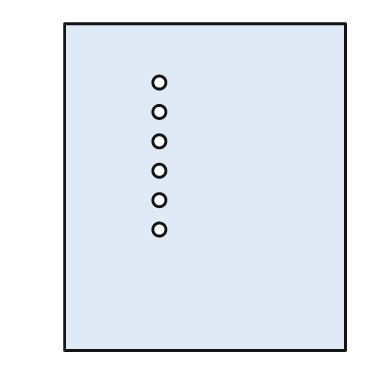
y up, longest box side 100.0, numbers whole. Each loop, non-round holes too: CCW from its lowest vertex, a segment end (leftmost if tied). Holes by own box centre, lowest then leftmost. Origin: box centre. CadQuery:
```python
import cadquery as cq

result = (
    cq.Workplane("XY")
    .moveTo(-43.0, -50.0)
    .lineTo(43.0, -50.0)
    .lineTo(43.0, 50.0)
    .lineTo(-43.0, 50.0)
    .close()
    .moveTo(-14.0, -13.0)
    .circle(2.0)
    .moveTo(-14.0, -4.0)
    .circle(2.0)
    .moveTo(-14.0, 5.0)
    .circle(2.0)
    .moveTo(-14.0, 14.0)
    .circle(2.0)
    .moveTo(-14.0, 23.0)
    .circle(2.0)
    .moveTo(-14.0, 32.0)
    .circle(2.0)
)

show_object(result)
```